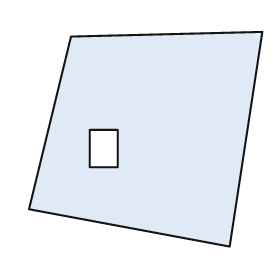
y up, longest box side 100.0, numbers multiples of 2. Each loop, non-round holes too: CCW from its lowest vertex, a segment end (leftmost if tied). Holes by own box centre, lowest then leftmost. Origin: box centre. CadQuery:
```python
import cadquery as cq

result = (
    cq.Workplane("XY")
    .moveTo(36.0, -46.0)
    .lineTo(50.0, 46.0)
    .lineTo(-32.0, 44.0)
    .lineTo(-50.0, -30.0)
    .close()
    .moveTo(-24.0, -12.0)
    .lineTo(-12.0, -12.0)
    .lineTo(-12.0, 4.0)
    .lineTo(-24.0, 4.0)
    .close()
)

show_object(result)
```